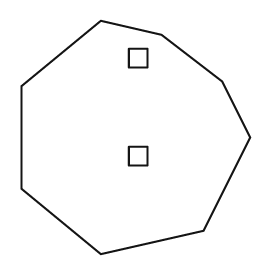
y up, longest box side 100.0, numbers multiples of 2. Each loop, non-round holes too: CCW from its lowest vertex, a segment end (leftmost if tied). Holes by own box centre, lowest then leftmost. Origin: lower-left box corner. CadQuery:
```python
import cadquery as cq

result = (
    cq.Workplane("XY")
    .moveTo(34.0, 0.0)
    .lineTo(78.0, 10.0)
    .lineTo(98.0, 50.0)
    .lineTo(86.0, 74.0)
    .lineTo(60.0, 94.0)
    .lineTo(34.0, 100.0)
    .lineTo(0.0, 72.0)
    .lineTo(0.0, 28.0)
    .close()
    .moveTo(46.0, 38.0)
    .lineTo(54.0, 38.0)
    .lineTo(54.0, 46.0)
    .lineTo(46.0, 46.0)
    .close()
    .moveTo(46.0, 80.0)
    .lineTo(54.0, 80.0)
    .lineTo(54.0, 88.0)
    .lineTo(46.0, 88.0)
    .close()
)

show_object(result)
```